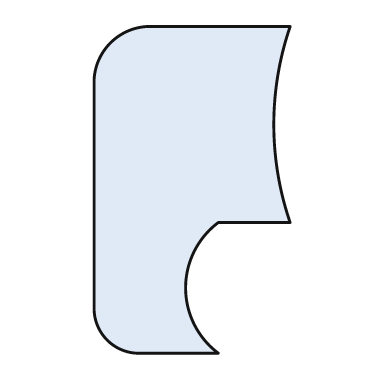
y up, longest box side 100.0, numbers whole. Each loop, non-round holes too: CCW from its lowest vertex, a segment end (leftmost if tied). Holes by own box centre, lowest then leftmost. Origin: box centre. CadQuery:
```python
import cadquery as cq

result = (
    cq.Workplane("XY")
    .moveTo(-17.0, -50.0)
    .lineTo(8.0, -50.0)
    .threePointArc((-2.0, -30.0), (8.0, -10.0))
    .lineTo(30.0, -10.0)
    .threePointArc((25.0, 20.0), (30.0, 50.0))
    .lineTo(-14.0, 50.0)
    .threePointArc((-25.0, 45.0), (-30.0, 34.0))
    .lineTo(-30.0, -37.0)
    .threePointArc((-26.0, -46.0), (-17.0, -50.0))
    .close()
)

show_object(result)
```